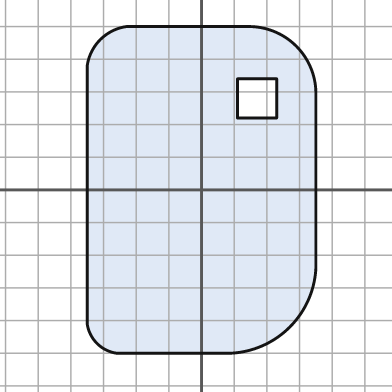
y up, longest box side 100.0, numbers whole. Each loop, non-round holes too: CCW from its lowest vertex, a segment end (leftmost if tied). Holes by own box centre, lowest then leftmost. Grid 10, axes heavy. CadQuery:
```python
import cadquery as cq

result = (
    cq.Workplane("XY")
    .moveTo(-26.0, -50.0)
    .lineTo(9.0, -50.0)
    .threePointArc((27.0, -42.0), (35.0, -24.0))
    .lineTo(35.0, 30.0)
    .threePointArc((29.0, 44.0), (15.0, 50.0))
    .lineTo(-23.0, 50.0)
    .threePointArc((-31.0, 46.0), (-35.0, 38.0))
    .lineTo(-35.0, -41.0)
    .threePointArc((-32.0, -47.0), (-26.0, -50.0))
    .close()
    .moveTo(11.0, 22.0)
    .lineTo(23.0, 22.0)
    .lineTo(23.0, 34.0)
    .lineTo(11.0, 34.0)
    .close()
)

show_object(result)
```